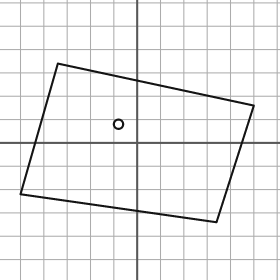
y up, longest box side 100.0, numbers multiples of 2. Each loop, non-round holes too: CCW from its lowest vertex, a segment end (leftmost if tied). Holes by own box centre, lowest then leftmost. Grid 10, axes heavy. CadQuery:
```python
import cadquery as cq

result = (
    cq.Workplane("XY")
    .moveTo(34.0, -34.0)
    .lineTo(50.0, 16.0)
    .lineTo(-34.0, 34.0)
    .lineTo(-50.0, -22.0)
    .close()
    .moveTo(-8.0, 8.0)
    .circle(2.0)
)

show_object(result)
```